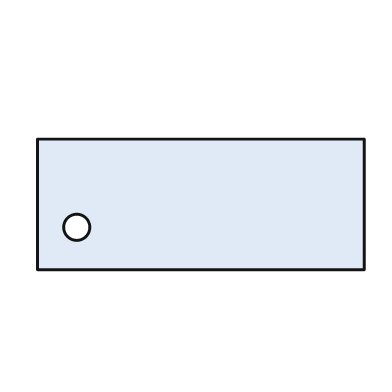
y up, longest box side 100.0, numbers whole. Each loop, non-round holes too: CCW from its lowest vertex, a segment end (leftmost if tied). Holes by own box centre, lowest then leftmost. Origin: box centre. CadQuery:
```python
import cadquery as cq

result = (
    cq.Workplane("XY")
    .moveTo(-50.0, -20.0)
    .lineTo(50.0, -20.0)
    .lineTo(50.0, 20.0)
    .lineTo(-50.0, 20.0)
    .close()
    .moveTo(-38.0, -7.0)
    .circle(4.0)
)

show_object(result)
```